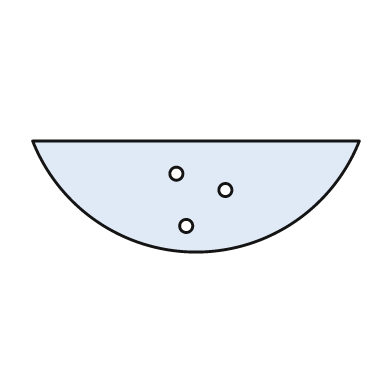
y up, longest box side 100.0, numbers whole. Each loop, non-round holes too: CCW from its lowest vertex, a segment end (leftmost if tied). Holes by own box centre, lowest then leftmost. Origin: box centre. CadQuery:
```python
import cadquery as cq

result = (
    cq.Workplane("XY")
    .moveTo(-50.0, 17.0)
    .threePointArc((0.0, -17.0), (50.0, 17.0))
    .close()
    .moveTo(-3.0, -9.0)
    .circle(2.0)
    .moveTo(9.0, 2.0)
    .circle(2.0)
    .moveTo(-6.0, 7.0)
    .circle(2.0)
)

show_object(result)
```